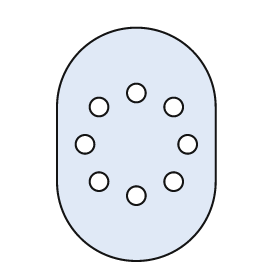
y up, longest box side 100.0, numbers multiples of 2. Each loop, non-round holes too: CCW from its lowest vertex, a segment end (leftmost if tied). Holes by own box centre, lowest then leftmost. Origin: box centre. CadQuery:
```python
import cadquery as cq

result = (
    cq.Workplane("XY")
    .moveTo(-34.0, -16.0)
    .threePointArc((0.0, -50.0), (34.0, -16.0))
    .lineTo(34.0, 16.0)
    .threePointArc((0.0, 50.0), (-34.0, 16.0))
    .close()
    .moveTo(0.0, -22.0)
    .circle(4.0)
    .moveTo(-16.0, -16.0)
    .circle(4.0)
    .moveTo(16.0, -16.0)
    .circle(4.0)
    .moveTo(-22.0, 0.0)
    .circle(4.0)
    .moveTo(22.0, 0.0)
    .circle(4.0)
    .moveTo(-16.0, 16.0)
    .circle(4.0)
    .moveTo(16.0, 16.0)
    .circle(4.0)
    .moveTo(0.0, 22.0)
    .circle(4.0)
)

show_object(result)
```